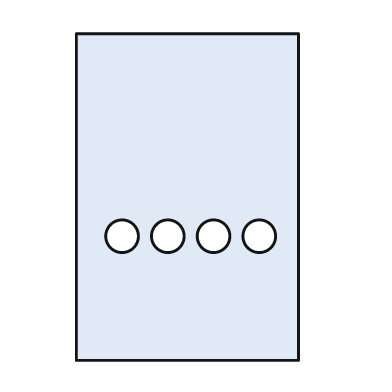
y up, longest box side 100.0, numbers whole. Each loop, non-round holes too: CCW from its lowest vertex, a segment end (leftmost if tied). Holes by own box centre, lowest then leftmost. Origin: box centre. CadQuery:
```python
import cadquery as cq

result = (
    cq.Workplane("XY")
    .moveTo(-34.0, -50.0)
    .lineTo(34.0, -50.0)
    .lineTo(34.0, 50.0)
    .lineTo(-34.0, 50.0)
    .close()
    .moveTo(-20.0, -12.0)
    .circle(5.0)
    .moveTo(-6.0, -12.0)
    .circle(5.0)
    .moveTo(8.0, -12.0)
    .circle(5.0)
    .moveTo(22.0, -12.0)
    .circle(5.0)
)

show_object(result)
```